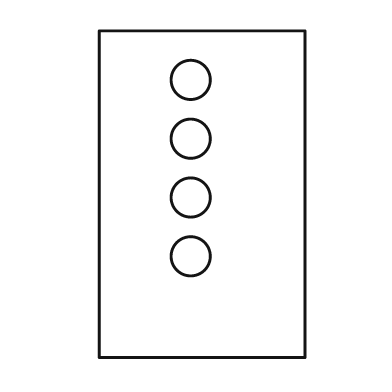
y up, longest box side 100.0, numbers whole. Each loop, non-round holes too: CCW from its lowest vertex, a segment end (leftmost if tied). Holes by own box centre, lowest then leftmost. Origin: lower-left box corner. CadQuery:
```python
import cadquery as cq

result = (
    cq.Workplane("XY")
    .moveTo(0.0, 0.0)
    .lineTo(63.0, 0.0)
    .lineTo(63.0, 100.0)
    .lineTo(0.0, 100.0)
    .close()
    .moveTo(28.0, 31.0)
    .circle(6.0)
    .moveTo(28.0, 49.0)
    .circle(6.0)
    .moveTo(28.0, 67.0)
    .circle(6.0)
    .moveTo(28.0, 85.0)
    .circle(6.0)
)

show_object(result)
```